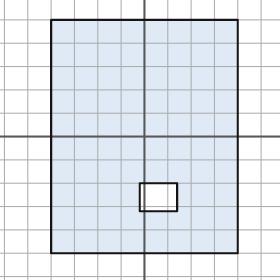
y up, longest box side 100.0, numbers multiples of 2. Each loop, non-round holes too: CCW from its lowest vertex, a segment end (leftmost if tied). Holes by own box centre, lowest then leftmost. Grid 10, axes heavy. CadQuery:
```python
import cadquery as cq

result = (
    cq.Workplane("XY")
    .moveTo(-40.0, -50.0)
    .lineTo(40.0, -50.0)
    .lineTo(40.0, 50.0)
    .lineTo(-40.0, 50.0)
    .close()
    .moveTo(-2.0, -32.0)
    .lineTo(14.0, -32.0)
    .lineTo(14.0, -20.0)
    .lineTo(-2.0, -20.0)
    .close()
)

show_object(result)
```